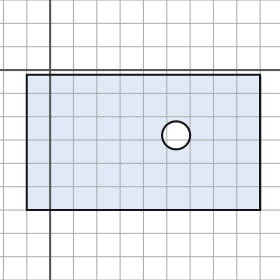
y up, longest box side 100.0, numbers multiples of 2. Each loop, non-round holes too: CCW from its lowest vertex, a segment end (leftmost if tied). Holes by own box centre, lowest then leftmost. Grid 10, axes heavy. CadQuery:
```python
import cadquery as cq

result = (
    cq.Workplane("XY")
    .moveTo(-10.0, -60.0)
    .lineTo(90.0, -60.0)
    .lineTo(90.0, -2.0)
    .lineTo(-10.0, -2.0)
    .close()
    .moveTo(54.0, -28.0)
    .circle(6.0)
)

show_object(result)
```